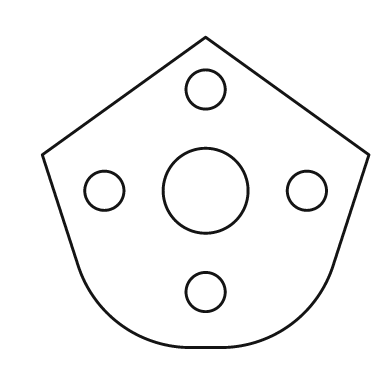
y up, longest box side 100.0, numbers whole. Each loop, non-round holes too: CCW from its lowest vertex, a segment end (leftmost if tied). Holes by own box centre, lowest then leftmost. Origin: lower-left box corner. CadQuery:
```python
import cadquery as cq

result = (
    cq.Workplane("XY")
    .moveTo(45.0, 0.0)
    .lineTo(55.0, 0.0)
    .threePointArc((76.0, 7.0), (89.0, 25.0))
    .lineTo(100.0, 59.0)
    .lineTo(50.0, 95.0)
    .lineTo(0.0, 59.0)
    .lineTo(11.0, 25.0)
    .threePointArc((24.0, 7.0), (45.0, 0.0))
    .close()
    .moveTo(50.0, 17.0)
    .circle(6.0)
    .moveTo(19.0, 48.0)
    .circle(6.0)
    .moveTo(50.0, 48.0)
    .circle(13.0)
    .moveTo(81.0, 48.0)
    .circle(6.0)
    .moveTo(50.0, 79.0)
    .circle(6.0)
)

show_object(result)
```